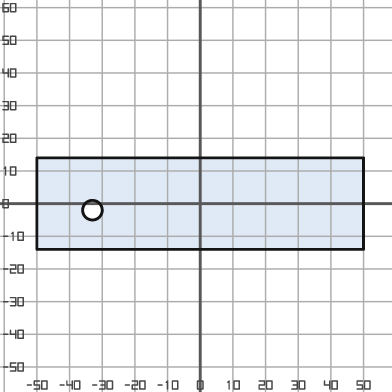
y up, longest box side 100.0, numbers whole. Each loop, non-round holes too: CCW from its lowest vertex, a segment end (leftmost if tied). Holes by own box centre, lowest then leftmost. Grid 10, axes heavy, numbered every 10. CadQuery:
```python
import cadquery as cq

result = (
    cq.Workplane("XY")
    .moveTo(-50.0, -14.0)
    .lineTo(50.0, -14.0)
    .lineTo(50.0, 14.0)
    .lineTo(-50.0, 14.0)
    .close()
    .moveTo(-33.0, -2.0)
    .circle(3.0)
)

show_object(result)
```